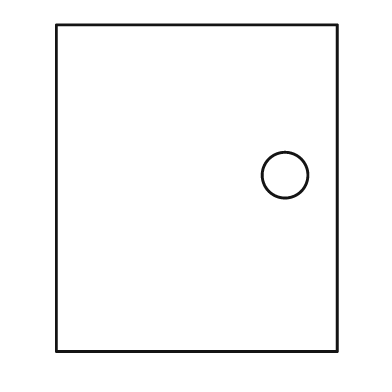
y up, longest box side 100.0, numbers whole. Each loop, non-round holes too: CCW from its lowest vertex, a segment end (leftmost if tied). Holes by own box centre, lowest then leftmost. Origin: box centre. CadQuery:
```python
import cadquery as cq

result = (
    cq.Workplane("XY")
    .moveTo(-43.0, -50.0)
    .lineTo(43.0, -50.0)
    .lineTo(43.0, 50.0)
    .lineTo(-43.0, 50.0)
    .close()
    .moveTo(27.0, 4.0)
    .circle(7.0)
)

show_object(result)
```